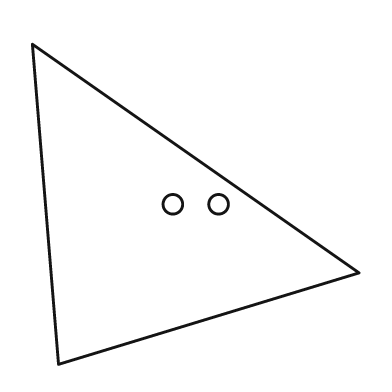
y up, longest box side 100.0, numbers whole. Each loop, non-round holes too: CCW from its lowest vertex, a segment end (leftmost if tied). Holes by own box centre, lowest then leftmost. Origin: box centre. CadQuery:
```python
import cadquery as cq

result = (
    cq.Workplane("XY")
    .moveTo(-42.0, -49.0)
    .lineTo(50.0, -21.0)
    .lineTo(-50.0, 49.0)
    .close()
    .moveTo(-7.0, 0.0)
    .circle(3.0)
    .moveTo(7.0, 0.0)
    .circle(3.0)
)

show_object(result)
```